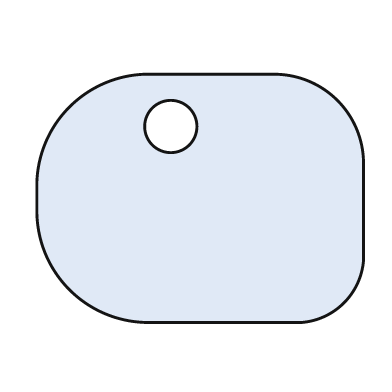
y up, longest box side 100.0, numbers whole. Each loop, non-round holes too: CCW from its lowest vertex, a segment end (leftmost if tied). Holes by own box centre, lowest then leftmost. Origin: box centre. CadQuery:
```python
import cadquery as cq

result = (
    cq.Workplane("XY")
    .moveTo(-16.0, -38.0)
    .lineTo(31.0, -38.0)
    .threePointArc((44.0, -32.0), (50.0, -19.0))
    .lineTo(50.0, 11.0)
    .threePointArc((42.0, 30.0), (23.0, 38.0))
    .lineTo(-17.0, 38.0)
    .threePointArc((-40.0, 28.0), (-50.0, 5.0))
    .lineTo(-50.0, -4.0)
    .threePointArc((-40.0, -28.0), (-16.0, -38.0))
    .close()
    .moveTo(-9.0, 22.0)
    .circle(8.0)
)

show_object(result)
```